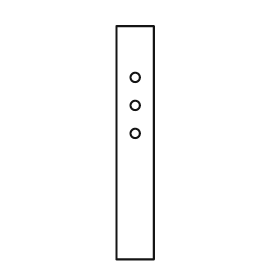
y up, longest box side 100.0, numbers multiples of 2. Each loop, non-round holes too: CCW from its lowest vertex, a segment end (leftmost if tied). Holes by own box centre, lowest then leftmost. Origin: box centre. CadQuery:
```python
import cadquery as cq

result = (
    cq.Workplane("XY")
    .moveTo(-8.0, -50.0)
    .lineTo(8.0, -50.0)
    .lineTo(8.0, 50.0)
    .lineTo(-8.0, 50.0)
    .close()
    .moveTo(0.0, 4.0)
    .circle(2.0)
    .moveTo(0.0, 16.0)
    .circle(2.0)
    .moveTo(0.0, 28.0)
    .circle(2.0)
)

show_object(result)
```